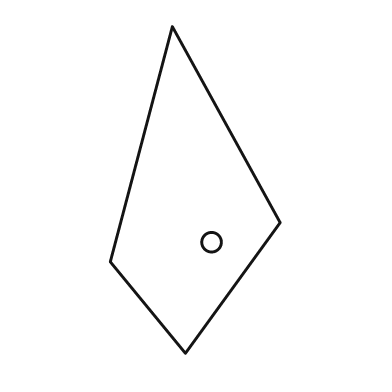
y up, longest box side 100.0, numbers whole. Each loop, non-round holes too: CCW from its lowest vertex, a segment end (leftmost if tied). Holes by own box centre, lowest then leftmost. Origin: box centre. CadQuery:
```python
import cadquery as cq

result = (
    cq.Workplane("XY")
    .moveTo(-3.0, -50.0)
    .lineTo(26.0, -10.0)
    .lineTo(-7.0, 50.0)
    .lineTo(-26.0, -22.0)
    .close()
    .moveTo(5.0, -16.0)
    .circle(3.0)
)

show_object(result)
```